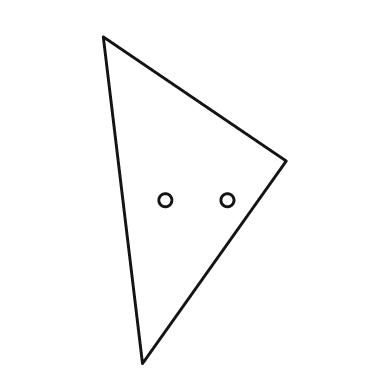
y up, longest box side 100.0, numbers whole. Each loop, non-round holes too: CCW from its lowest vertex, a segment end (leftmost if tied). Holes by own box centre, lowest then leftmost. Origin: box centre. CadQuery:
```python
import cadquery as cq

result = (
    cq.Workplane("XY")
    .moveTo(-16.0, -50.0)
    .lineTo(28.0, 12.0)
    .lineTo(-28.0, 50.0)
    .close()
    .moveTo(-9.0, 0.0)
    .circle(2.0)
    .moveTo(10.0, 0.0)
    .circle(2.0)
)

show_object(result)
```